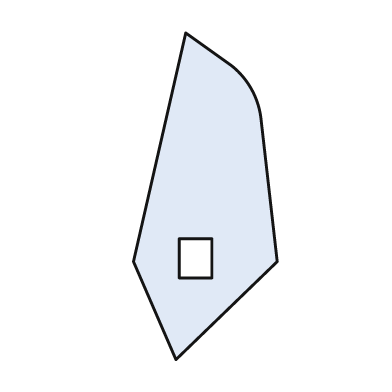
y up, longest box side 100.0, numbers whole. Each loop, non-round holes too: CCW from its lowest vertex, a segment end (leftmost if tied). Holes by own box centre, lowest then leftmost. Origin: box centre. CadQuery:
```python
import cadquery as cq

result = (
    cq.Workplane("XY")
    .moveTo(-9.0, -50.0)
    .lineTo(22.0, -20.0)
    .lineTo(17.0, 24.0)
    .threePointArc((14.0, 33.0), (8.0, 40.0))
    .lineTo(-6.0, 50.0)
    .lineTo(-22.0, -20.0)
    .close()
    .moveTo(-8.0, -25.0)
    .lineTo(2.0, -25.0)
    .lineTo(2.0, -13.0)
    .lineTo(-8.0, -13.0)
    .close()
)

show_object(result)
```